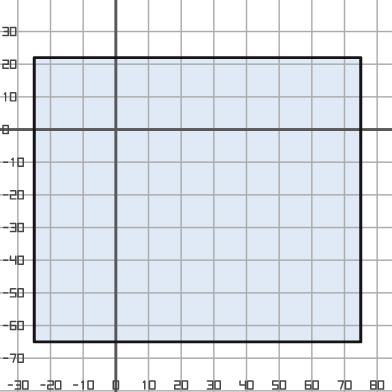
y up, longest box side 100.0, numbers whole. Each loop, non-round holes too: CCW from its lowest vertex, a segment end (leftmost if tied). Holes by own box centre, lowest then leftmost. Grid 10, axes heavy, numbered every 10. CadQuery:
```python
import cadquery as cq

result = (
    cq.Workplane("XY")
    .moveTo(-25.0, -65.0)
    .lineTo(75.0, -65.0)
    .lineTo(75.0, 22.0)
    .lineTo(-25.0, 22.0)
    .close()
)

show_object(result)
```